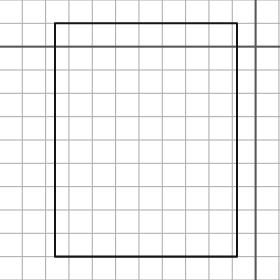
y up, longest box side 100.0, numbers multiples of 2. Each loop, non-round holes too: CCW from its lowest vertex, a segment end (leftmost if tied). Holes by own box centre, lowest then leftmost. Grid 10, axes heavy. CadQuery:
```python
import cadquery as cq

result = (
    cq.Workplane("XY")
    .moveTo(-86.0, -90.0)
    .lineTo(-8.0, -90.0)
    .lineTo(-8.0, 10.0)
    .lineTo(-86.0, 10.0)
    .close()
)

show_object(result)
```